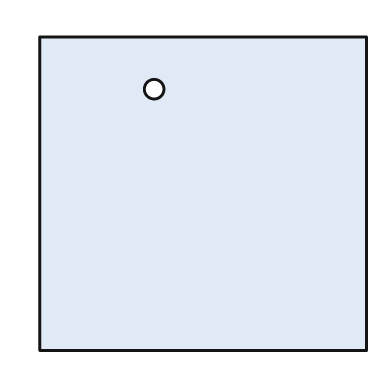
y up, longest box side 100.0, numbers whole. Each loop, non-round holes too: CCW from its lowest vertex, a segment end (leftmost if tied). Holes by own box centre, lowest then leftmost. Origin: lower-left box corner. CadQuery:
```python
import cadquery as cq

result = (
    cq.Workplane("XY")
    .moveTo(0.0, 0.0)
    .lineTo(100.0, 0.0)
    .lineTo(100.0, 96.0)
    .lineTo(0.0, 96.0)
    .close()
    .moveTo(35.0, 80.0)
    .circle(3.0)
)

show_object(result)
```